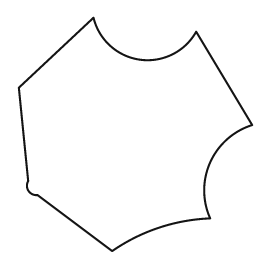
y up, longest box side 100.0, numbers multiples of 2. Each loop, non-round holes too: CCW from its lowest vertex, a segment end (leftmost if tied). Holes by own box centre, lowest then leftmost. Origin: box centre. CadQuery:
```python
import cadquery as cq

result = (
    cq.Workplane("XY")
    .moveTo(-10.0, -50.0)
    .threePointArc((10.0, -40.0), (32.0, -36.0))
    .threePointArc((32.0, -12.0), (50.0, 4.0))
    .lineTo(26.0, 44.0)
    .threePointArc((2.0, 32.0), (-18.0, 50.0))
    .lineTo(-50.0, 20.0)
    .lineTo(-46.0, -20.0)
    .threePointArc((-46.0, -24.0), (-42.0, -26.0))
    .close()
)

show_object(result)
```